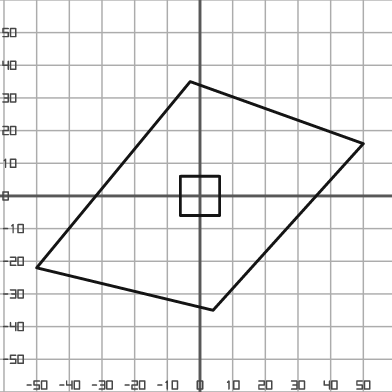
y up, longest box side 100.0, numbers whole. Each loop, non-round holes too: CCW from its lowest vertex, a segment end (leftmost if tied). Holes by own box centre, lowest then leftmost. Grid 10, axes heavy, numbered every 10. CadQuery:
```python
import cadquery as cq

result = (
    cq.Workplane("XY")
    .moveTo(4.0, -35.0)
    .lineTo(50.0, 16.0)
    .lineTo(-3.0, 35.0)
    .lineTo(-50.0, -22.0)
    .close()
    .moveTo(-6.0, -6.0)
    .lineTo(6.0, -6.0)
    .lineTo(6.0, 6.0)
    .lineTo(-6.0, 6.0)
    .close()
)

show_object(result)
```